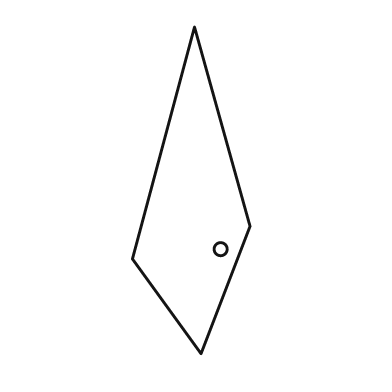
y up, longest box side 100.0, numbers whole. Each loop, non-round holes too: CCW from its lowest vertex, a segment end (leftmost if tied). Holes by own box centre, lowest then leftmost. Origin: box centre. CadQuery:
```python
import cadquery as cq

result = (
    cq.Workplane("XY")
    .moveTo(3.0, -50.0)
    .lineTo(18.0, -11.0)
    .lineTo(1.0, 50.0)
    .lineTo(-18.0, -21.0)
    .close()
    .moveTo(9.0, -18.0)
    .circle(2.0)
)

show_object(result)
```